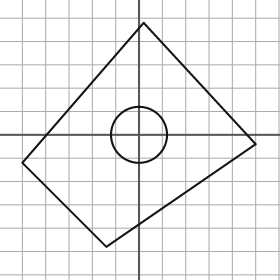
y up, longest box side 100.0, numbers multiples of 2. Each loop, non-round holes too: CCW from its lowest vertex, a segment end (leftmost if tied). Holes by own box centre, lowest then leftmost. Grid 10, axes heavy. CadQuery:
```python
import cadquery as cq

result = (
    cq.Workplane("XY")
    .moveTo(-14.0, -48.0)
    .lineTo(50.0, -4.0)
    .lineTo(2.0, 48.0)
    .lineTo(-50.0, -12.0)
    .close()
    .moveTo(0.0, 0.0)
    .circle(12.0)
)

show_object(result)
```